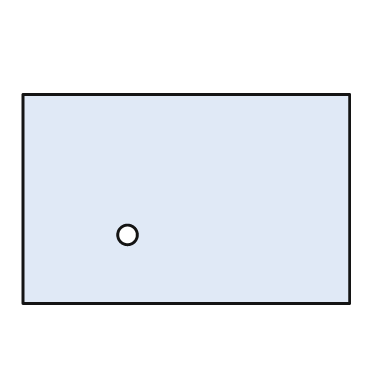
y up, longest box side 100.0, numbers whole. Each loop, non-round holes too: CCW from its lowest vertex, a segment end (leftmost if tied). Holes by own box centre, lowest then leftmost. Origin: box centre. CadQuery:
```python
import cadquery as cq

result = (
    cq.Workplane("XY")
    .moveTo(-50.0, -32.0)
    .lineTo(50.0, -32.0)
    .lineTo(50.0, 32.0)
    .lineTo(-50.0, 32.0)
    .close()
    .moveTo(-18.0, -11.0)
    .circle(3.0)
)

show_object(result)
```